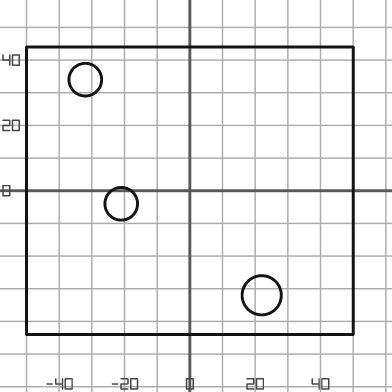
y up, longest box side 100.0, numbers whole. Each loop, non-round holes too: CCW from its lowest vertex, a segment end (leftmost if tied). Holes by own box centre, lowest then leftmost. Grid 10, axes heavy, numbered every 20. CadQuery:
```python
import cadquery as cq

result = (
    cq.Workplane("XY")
    .moveTo(-50.0, -44.0)
    .lineTo(50.0, -44.0)
    .lineTo(50.0, 44.0)
    .lineTo(-50.0, 44.0)
    .close()
    .moveTo(22.0, -32.0)
    .circle(6.0)
    .moveTo(-21.0, -4.0)
    .circle(5.0)
    .moveTo(-32.0, 34.0)
    .circle(5.0)
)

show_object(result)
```